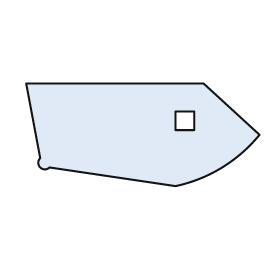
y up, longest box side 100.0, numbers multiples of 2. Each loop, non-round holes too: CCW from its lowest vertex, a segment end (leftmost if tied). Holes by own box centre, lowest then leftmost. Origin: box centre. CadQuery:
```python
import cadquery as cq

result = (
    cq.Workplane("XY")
    .moveTo(14.0, -22.0)
    .threePointArc((34.0, -14.0), (50.0, 0.0))
    .lineTo(26.0, 22.0)
    .lineTo(-50.0, 22.0)
    .lineTo(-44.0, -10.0)
    .threePointArc((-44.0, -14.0), (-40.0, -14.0))
    .close()
    .moveTo(14.0, 2.0)
    .lineTo(22.0, 2.0)
    .lineTo(22.0, 10.0)
    .lineTo(14.0, 10.0)
    .close()
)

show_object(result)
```